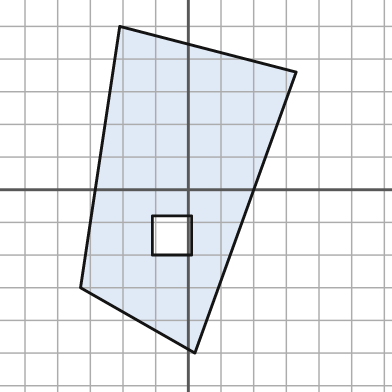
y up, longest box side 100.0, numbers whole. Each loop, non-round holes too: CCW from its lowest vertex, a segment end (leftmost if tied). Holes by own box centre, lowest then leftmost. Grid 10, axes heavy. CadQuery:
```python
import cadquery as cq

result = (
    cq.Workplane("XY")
    .moveTo(2.0, -50.0)
    .lineTo(33.0, 36.0)
    .lineTo(-21.0, 50.0)
    .lineTo(-33.0, -30.0)
    .close()
    .moveTo(-11.0, -20.0)
    .lineTo(1.0, -20.0)
    .lineTo(1.0, -8.0)
    .lineTo(-11.0, -8.0)
    .close()
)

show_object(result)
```